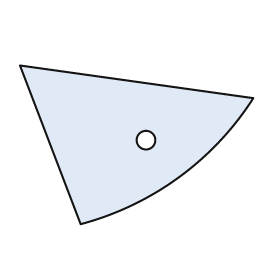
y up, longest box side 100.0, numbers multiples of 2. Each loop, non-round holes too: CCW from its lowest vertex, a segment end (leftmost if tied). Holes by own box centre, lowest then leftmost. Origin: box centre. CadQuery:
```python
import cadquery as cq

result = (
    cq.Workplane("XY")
    .moveTo(-24.0, -34.0)
    .threePointArc((18.0, -14.0), (50.0, 20.0))
    .lineTo(-50.0, 34.0)
    .close()
    .moveTo(4.0, 2.0)
    .circle(4.0)
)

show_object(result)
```